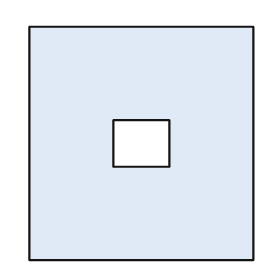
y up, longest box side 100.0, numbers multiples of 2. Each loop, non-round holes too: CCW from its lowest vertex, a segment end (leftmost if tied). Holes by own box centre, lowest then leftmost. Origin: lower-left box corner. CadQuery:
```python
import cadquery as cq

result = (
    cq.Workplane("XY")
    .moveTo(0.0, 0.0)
    .lineTo(96.0, 0.0)
    .lineTo(96.0, 100.0)
    .lineTo(0.0, 100.0)
    .close()
    .moveTo(36.0, 40.0)
    .lineTo(60.0, 40.0)
    .lineTo(60.0, 60.0)
    .lineTo(36.0, 60.0)
    .close()
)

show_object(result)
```